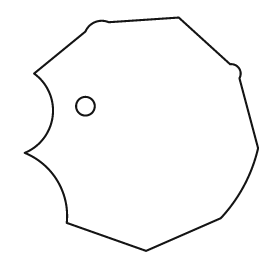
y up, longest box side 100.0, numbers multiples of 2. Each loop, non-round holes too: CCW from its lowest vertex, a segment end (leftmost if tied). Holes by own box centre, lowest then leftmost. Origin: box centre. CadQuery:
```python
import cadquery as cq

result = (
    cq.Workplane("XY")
    .moveTo(2.0, -50.0)
    .lineTo(34.0, -36.0)
    .threePointArc((44.0, -22.0), (50.0, -6.0))
    .lineTo(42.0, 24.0)
    .threePointArc((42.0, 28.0), (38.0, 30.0))
    .lineTo(16.0, 50.0)
    .lineTo(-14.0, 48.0)
    .threePointArc((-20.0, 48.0), (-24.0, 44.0))
    .lineTo(-46.0, 26.0)
    .threePointArc((-38.0, 8.0), (-50.0, -8.0))
    .threePointArc((-36.0, -20.0), (-32.0, -38.0))
    .close()
    .moveTo(-24.0, 12.0)
    .circle(4.0)
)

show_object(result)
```